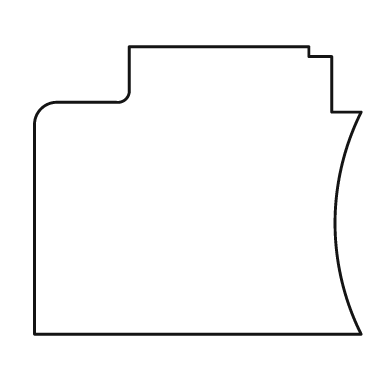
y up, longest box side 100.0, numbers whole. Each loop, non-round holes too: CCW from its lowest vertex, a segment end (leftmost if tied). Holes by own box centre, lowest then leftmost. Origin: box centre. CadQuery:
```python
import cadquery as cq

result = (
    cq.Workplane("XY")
    .moveTo(-50.0, -44.0)
    .lineTo(50.0, -44.0)
    .threePointArc((42.0, -10.0), (50.0, 24.0))
    .lineTo(41.0, 24.0)
    .lineTo(41.0, 41.0)
    .lineTo(34.0, 41.0)
    .lineTo(34.0, 44.0)
    .lineTo(-21.0, 44.0)
    .lineTo(-21.0, 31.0)
    .threePointArc((-22.0, 28.0), (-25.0, 27.0))
    .lineTo(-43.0, 27.0)
    .threePointArc((-48.0, 25.0), (-50.0, 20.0))
    .close()
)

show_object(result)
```